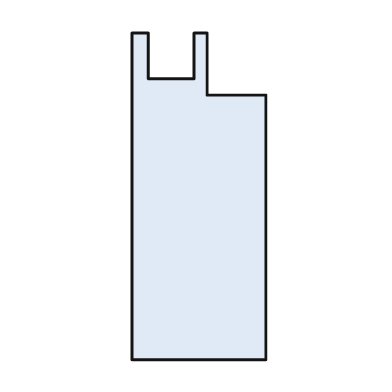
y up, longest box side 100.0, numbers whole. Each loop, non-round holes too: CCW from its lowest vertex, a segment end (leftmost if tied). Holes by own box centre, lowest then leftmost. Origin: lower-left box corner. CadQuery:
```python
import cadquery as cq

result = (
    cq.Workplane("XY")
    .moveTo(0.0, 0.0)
    .lineTo(41.0, 0.0)
    .lineTo(41.0, 81.0)
    .lineTo(23.0, 81.0)
    .lineTo(23.0, 100.0)
    .lineTo(19.0, 100.0)
    .lineTo(19.0, 86.0)
    .lineTo(5.0, 86.0)
    .lineTo(5.0, 100.0)
    .lineTo(0.0, 100.0)
    .close()
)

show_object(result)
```